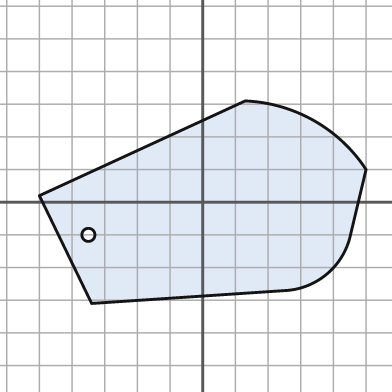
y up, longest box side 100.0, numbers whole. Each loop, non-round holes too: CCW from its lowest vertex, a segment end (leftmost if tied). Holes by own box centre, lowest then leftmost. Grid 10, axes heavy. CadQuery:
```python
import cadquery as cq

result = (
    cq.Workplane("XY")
    .moveTo(-34.0, -31.0)
    .lineTo(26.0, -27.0)
    .threePointArc((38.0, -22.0), (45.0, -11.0))
    .lineTo(50.0, 10.0)
    .threePointArc((34.0, 25.0), (13.0, 31.0))
    .lineTo(-50.0, 2.0)
    .close()
    .moveTo(-35.0, -10.0)
    .circle(2.0)
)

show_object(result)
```